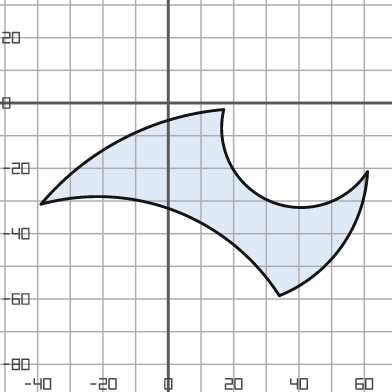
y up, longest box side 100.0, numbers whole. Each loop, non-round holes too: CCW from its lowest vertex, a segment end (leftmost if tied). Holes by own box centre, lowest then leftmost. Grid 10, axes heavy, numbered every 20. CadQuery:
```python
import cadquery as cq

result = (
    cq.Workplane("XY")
    .moveTo(34.0, -59.0)
    .threePointArc((53.0, -44.0), (61.0, -21.0))
    .threePointArc((31.0, -30.0), (17.0, -2.0))
    .threePointArc((-14.0, -11.0), (-39.0, -31.0))
    .threePointArc((2.0, -33.0), (34.0, -59.0))
    .close()
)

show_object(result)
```